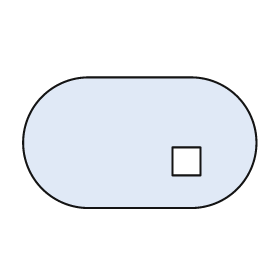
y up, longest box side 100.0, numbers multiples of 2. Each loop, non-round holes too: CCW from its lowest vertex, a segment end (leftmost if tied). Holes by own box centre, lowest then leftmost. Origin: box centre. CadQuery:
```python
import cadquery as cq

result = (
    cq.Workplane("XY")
    .moveTo(-22.0, -28.0)
    .lineTo(22.0, -28.0)
    .threePointArc((50.0, 0.0), (22.0, 28.0))
    .lineTo(-22.0, 28.0)
    .threePointArc((-50.0, 0.0), (-22.0, -28.0))
    .close()
    .moveTo(14.0, -14.0)
    .lineTo(26.0, -14.0)
    .lineTo(26.0, -2.0)
    .lineTo(14.0, -2.0)
    .close()
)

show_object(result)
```